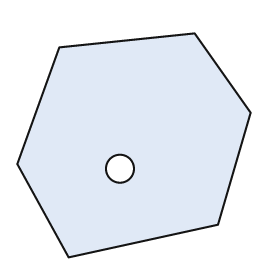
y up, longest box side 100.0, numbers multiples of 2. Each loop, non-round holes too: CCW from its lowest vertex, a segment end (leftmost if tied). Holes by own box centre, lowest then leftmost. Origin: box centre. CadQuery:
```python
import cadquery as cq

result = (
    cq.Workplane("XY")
    .moveTo(-28.0, -48.0)
    .lineTo(36.0, -34.0)
    .lineTo(50.0, 14.0)
    .lineTo(26.0, 48.0)
    .lineTo(-32.0, 42.0)
    .lineTo(-50.0, -8.0)
    .close()
    .moveTo(-6.0, -10.0)
    .circle(6.0)
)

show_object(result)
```